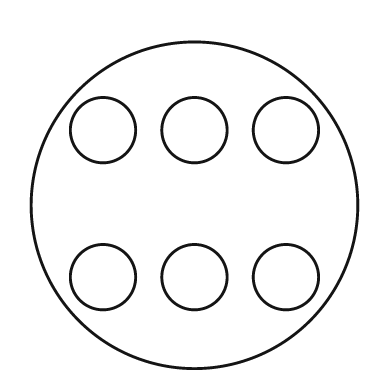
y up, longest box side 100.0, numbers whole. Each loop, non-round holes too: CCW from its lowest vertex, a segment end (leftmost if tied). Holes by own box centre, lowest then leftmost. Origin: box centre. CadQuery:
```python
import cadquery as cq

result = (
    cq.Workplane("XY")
    .moveTo(0.0, 0.0)
    .circle(50.0)
    .moveTo(-28.0, -22.0)
    .circle(10.0)
    .moveTo(0.0, -22.0)
    .circle(10.0)
    .moveTo(28.0, -22.0)
    .circle(10.0)
    .moveTo(-28.0, 23.0)
    .circle(10.0)
    .moveTo(0.0, 23.0)
    .circle(10.0)
    .moveTo(28.0, 23.0)
    .circle(10.0)
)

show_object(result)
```